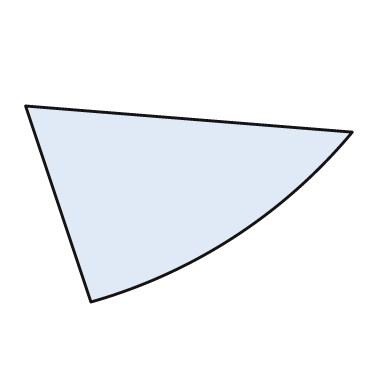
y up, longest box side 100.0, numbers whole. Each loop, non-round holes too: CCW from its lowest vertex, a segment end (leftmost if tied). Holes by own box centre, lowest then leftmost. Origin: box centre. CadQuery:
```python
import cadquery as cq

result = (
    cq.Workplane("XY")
    .moveTo(-30.0, -30.0)
    .threePointArc((14.0, -10.0), (50.0, 22.0))
    .lineTo(-50.0, 30.0)
    .close()
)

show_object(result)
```